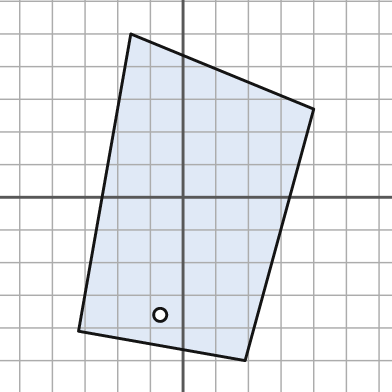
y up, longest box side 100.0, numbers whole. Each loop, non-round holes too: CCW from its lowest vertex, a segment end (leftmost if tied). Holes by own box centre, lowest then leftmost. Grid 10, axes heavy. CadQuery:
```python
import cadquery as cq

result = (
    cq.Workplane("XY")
    .moveTo(19.0, -50.0)
    .lineTo(40.0, 27.0)
    .lineTo(-16.0, 50.0)
    .lineTo(-32.0, -41.0)
    .close()
    .moveTo(-7.0, -36.0)
    .circle(2.0)
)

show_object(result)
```